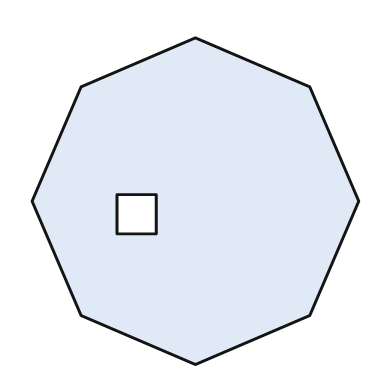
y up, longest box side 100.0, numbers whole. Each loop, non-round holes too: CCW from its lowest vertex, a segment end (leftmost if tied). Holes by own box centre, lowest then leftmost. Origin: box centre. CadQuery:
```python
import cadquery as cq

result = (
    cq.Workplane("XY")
    .moveTo(0.0, -50.0)
    .lineTo(35.0, -35.0)
    .lineTo(50.0, 0.0)
    .lineTo(35.0, 35.0)
    .lineTo(0.0, 50.0)
    .lineTo(-35.0, 35.0)
    .lineTo(-50.0, 0.0)
    .lineTo(-35.0, -35.0)
    .close()
    .moveTo(-24.0, -10.0)
    .lineTo(-12.0, -10.0)
    .lineTo(-12.0, 2.0)
    .lineTo(-24.0, 2.0)
    .close()
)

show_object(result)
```